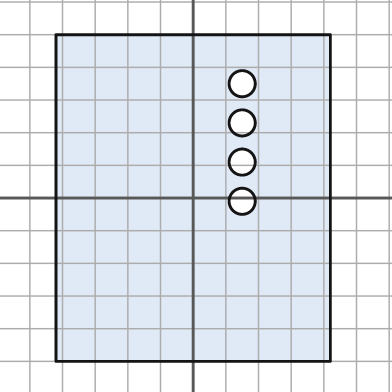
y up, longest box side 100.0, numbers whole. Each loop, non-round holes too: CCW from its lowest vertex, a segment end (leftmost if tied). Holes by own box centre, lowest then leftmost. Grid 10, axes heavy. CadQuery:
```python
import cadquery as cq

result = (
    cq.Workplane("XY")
    .moveTo(-42.0, -50.0)
    .lineTo(42.0, -50.0)
    .lineTo(42.0, 50.0)
    .lineTo(-42.0, 50.0)
    .close()
    .moveTo(15.0, -1.0)
    .circle(4.0)
    .moveTo(15.0, 11.0)
    .circle(4.0)
    .moveTo(15.0, 23.0)
    .circle(4.0)
    .moveTo(15.0, 35.0)
    .circle(4.0)
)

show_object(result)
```